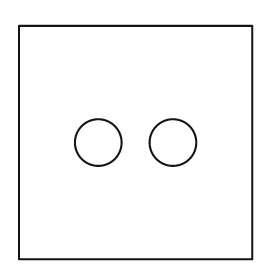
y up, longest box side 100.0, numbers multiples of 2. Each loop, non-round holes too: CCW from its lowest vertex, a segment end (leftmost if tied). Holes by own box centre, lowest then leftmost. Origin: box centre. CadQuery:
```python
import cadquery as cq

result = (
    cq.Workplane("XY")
    .moveTo(-50.0, -50.0)
    .lineTo(50.0, -50.0)
    .lineTo(50.0, 50.0)
    .lineTo(-50.0, 50.0)
    .close()
    .moveTo(-16.0, 0.0)
    .circle(10.0)
    .moveTo(16.0, 0.0)
    .circle(10.0)
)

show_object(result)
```